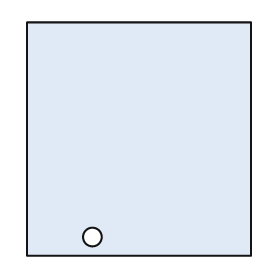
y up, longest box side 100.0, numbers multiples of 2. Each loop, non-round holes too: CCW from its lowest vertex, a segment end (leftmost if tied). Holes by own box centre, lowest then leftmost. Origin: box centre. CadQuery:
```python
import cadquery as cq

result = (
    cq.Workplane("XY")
    .moveTo(-48.0, -50.0)
    .lineTo(48.0, -50.0)
    .lineTo(48.0, 50.0)
    .lineTo(-48.0, 50.0)
    .close()
    .moveTo(-20.0, -42.0)
    .circle(4.0)
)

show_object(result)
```